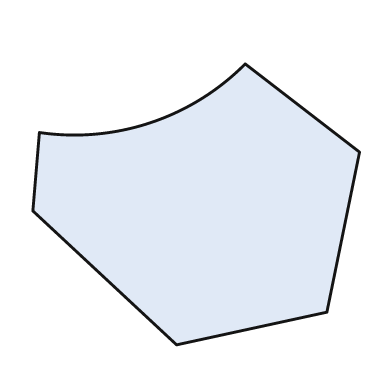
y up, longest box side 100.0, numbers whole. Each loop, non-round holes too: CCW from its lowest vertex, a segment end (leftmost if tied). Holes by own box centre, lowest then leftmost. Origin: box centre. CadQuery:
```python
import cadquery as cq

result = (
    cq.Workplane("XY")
    .moveTo(-6.0, -43.0)
    .lineTo(40.0, -33.0)
    .lineTo(50.0, 16.0)
    .lineTo(15.0, 43.0)
    .threePointArc((-14.0, 25.0), (-48.0, 22.0))
    .lineTo(-50.0, -2.0)
    .close()
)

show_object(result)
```